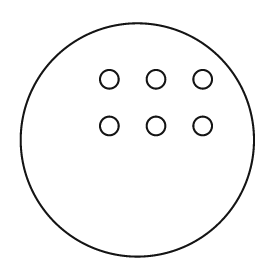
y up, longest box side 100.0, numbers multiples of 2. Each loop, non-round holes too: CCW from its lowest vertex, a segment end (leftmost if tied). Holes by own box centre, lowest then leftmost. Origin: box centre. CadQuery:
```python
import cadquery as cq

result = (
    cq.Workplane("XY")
    .moveTo(0.0, 0.0)
    .circle(50.0)
    .moveTo(-12.0, 6.0)
    .circle(4.0)
    .moveTo(8.0, 6.0)
    .circle(4.0)
    .moveTo(28.0, 6.0)
    .circle(4.0)
    .moveTo(-12.0, 26.0)
    .circle(4.0)
    .moveTo(8.0, 26.0)
    .circle(4.0)
    .moveTo(28.0, 26.0)
    .circle(4.0)
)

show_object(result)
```